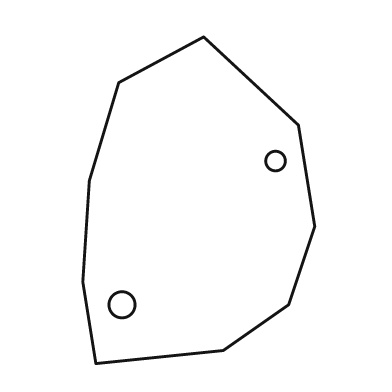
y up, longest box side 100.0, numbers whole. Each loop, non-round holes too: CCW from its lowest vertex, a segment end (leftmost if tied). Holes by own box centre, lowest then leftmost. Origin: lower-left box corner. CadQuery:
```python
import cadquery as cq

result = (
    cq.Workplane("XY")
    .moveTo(4.0, 0.0)
    .lineTo(43.0, 4.0)
    .lineTo(63.0, 18.0)
    .lineTo(71.0, 42.0)
    .lineTo(66.0, 73.0)
    .lineTo(37.0, 100.0)
    .lineTo(11.0, 86.0)
    .lineTo(2.0, 56.0)
    .lineTo(0.0, 25.0)
    .close()
    .moveTo(12.0, 18.0)
    .circle(4.0)
    .moveTo(59.0, 62.0)
    .circle(3.0)
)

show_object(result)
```